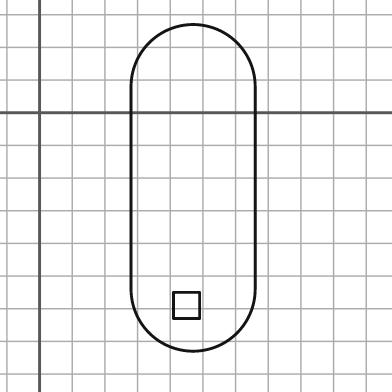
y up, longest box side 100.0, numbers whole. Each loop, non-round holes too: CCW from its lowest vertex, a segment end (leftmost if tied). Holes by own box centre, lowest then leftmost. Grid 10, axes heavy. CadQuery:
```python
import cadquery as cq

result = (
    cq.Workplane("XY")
    .moveTo(28.0, -54.0)
    .threePointArc((47.0, -73.0), (66.0, -54.0))
    .lineTo(66.0, 8.0)
    .threePointArc((47.0, 27.0), (28.0, 8.0))
    .close()
    .moveTo(41.0, -63.0)
    .lineTo(49.0, -63.0)
    .lineTo(49.0, -55.0)
    .lineTo(41.0, -55.0)
    .close()
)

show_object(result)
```